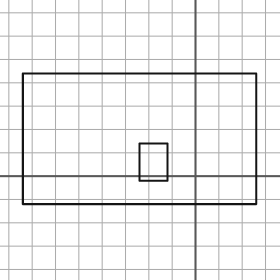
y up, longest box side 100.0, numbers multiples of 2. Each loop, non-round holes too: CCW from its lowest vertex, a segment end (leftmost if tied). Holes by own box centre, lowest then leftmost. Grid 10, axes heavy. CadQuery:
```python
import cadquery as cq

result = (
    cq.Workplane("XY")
    .moveTo(-74.0, -12.0)
    .lineTo(26.0, -12.0)
    .lineTo(26.0, 44.0)
    .lineTo(-74.0, 44.0)
    .close()
    .moveTo(-24.0, -2.0)
    .lineTo(-12.0, -2.0)
    .lineTo(-12.0, 14.0)
    .lineTo(-24.0, 14.0)
    .close()
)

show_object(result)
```